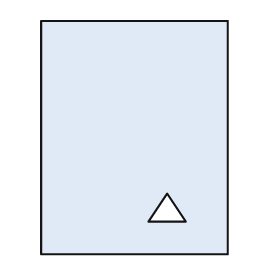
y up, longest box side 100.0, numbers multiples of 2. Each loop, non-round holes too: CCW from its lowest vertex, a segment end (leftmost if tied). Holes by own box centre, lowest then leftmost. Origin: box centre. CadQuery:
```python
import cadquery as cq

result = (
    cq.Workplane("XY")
    .moveTo(-40.0, -50.0)
    .lineTo(40.0, -50.0)
    .lineTo(40.0, 50.0)
    .lineTo(-40.0, 50.0)
    .close()
    .moveTo(6.0, -36.0)
    .lineTo(22.0, -36.0)
    .lineTo(14.0, -24.0)
    .close()
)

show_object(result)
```